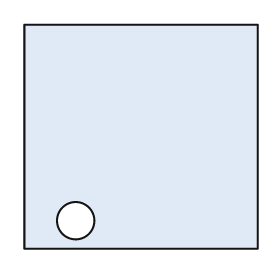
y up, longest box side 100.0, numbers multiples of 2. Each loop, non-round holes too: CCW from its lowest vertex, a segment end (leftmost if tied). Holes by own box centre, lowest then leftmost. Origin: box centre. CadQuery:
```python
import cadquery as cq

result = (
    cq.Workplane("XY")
    .moveTo(-50.0, -48.0)
    .lineTo(50.0, -48.0)
    .lineTo(50.0, 48.0)
    .lineTo(-50.0, 48.0)
    .close()
    .moveTo(-28.0, -36.0)
    .circle(8.0)
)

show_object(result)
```